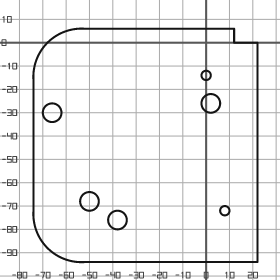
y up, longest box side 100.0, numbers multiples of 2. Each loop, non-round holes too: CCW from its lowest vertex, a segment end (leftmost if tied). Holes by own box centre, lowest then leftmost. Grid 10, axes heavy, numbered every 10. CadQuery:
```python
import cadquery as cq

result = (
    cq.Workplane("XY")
    .moveTo(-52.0, -94.0)
    .lineTo(22.0, -94.0)
    .lineTo(22.0, 0.0)
    .lineTo(12.0, 0.0)
    .lineTo(12.0, 6.0)
    .lineTo(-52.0, 6.0)
    .threePointArc((-68.0, 0.0), (-74.0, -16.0))
    .lineTo(-74.0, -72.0)
    .threePointArc((-68.0, -88.0), (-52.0, -94.0))
    .close()
    .moveTo(-38.0, -76.0)
    .circle(4.0)
    .moveTo(8.0, -72.0)
    .circle(2.0)
    .moveTo(-50.0, -68.0)
    .circle(4.0)
    .moveTo(-66.0, -30.0)
    .circle(4.0)
    .moveTo(2.0, -26.0)
    .circle(4.0)
    .moveTo(0.0, -14.0)
    .circle(2.0)
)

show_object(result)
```